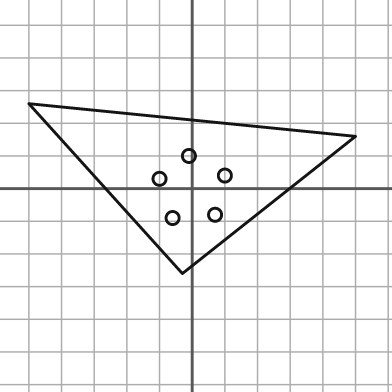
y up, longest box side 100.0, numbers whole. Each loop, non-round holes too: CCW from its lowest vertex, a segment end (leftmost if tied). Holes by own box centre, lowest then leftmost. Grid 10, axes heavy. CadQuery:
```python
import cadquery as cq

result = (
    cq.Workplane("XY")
    .moveTo(-3.0, -26.0)
    .lineTo(50.0, 16.0)
    .lineTo(-50.0, 26.0)
    .close()
    .moveTo(-6.0, -9.0)
    .circle(2.0)
    .moveTo(7.0, -8.0)
    .circle(2.0)
    .moveTo(-10.0, 3.0)
    .circle(2.0)
    .moveTo(10.0, 4.0)
    .circle(2.0)
    .moveTo(-1.0, 10.0)
    .circle(2.0)
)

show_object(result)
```